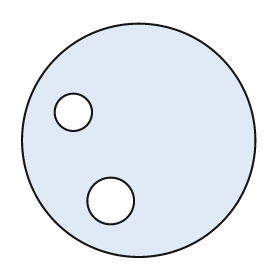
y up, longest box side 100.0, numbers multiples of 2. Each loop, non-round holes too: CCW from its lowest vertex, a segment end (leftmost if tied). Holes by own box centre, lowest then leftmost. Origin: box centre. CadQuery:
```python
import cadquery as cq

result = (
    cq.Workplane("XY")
    .moveTo(0.0, 0.0)
    .circle(50.0)
    .moveTo(-12.0, -26.0)
    .circle(10.0)
    .moveTo(-28.0, 12.0)
    .circle(8.0)
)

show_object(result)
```